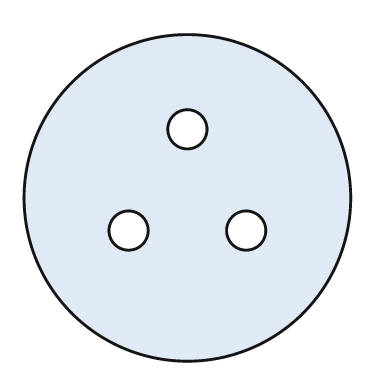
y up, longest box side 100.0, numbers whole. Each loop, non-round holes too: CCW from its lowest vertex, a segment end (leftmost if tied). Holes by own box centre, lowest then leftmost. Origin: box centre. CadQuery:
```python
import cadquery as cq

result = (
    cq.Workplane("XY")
    .moveTo(0.0, 0.0)
    .circle(50.0)
    .moveTo(-18.0, -10.0)
    .circle(6.0)
    .moveTo(18.0, -10.0)
    .circle(6.0)
    .moveTo(0.0, 21.0)
    .circle(6.0)
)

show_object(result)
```